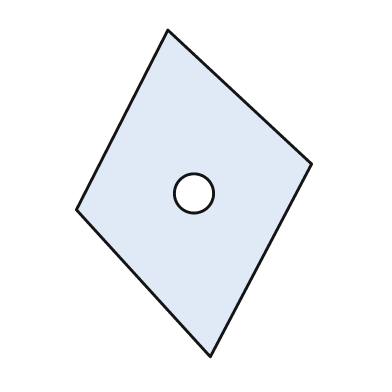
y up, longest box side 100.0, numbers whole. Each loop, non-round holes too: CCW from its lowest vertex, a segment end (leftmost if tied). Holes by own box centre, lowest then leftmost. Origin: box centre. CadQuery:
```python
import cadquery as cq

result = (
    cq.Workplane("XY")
    .moveTo(5.0, -50.0)
    .lineTo(36.0, 9.0)
    .lineTo(-8.0, 50.0)
    .lineTo(-36.0, -5.0)
    .close()
    .moveTo(0.0, 0.0)
    .circle(6.0)
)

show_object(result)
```